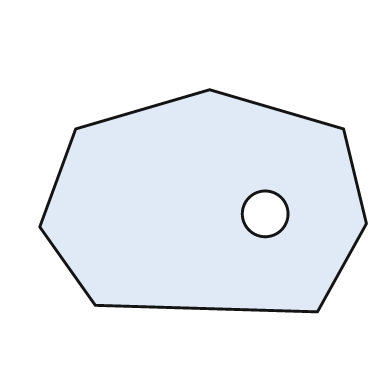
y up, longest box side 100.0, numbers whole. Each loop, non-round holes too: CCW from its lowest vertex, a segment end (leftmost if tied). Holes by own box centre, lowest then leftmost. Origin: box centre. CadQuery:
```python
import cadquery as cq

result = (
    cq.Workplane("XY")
    .moveTo(35.0, -34.0)
    .lineTo(50.0, -7.0)
    .lineTo(43.0, 22.0)
    .lineTo(2.0, 34.0)
    .lineTo(-39.0, 22.0)
    .lineTo(-50.0, -8.0)
    .lineTo(-33.0, -32.0)
    .close()
    .moveTo(19.0, -4.0)
    .circle(7.0)
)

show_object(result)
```